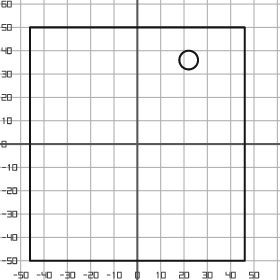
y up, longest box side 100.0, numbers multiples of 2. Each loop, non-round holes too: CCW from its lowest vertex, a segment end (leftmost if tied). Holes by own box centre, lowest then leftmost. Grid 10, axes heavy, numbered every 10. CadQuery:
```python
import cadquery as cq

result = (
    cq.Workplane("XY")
    .moveTo(-46.0, -50.0)
    .lineTo(46.0, -50.0)
    .lineTo(46.0, 50.0)
    .lineTo(-46.0, 50.0)
    .close()
    .moveTo(22.0, 36.0)
    .circle(4.0)
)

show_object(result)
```